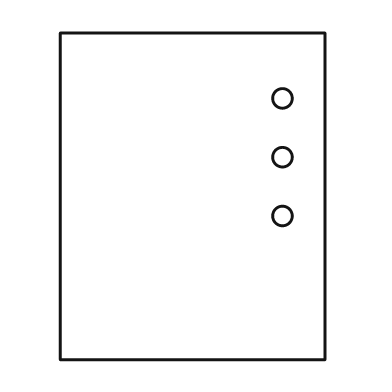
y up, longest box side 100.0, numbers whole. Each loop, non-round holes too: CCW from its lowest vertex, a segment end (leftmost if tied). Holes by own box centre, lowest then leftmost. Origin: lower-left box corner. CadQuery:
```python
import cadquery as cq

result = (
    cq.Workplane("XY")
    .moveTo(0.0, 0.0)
    .lineTo(81.0, 0.0)
    .lineTo(81.0, 100.0)
    .lineTo(0.0, 100.0)
    .close()
    .moveTo(68.0, 44.0)
    .circle(3.0)
    .moveTo(68.0, 62.0)
    .circle(3.0)
    .moveTo(68.0, 80.0)
    .circle(3.0)
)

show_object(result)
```